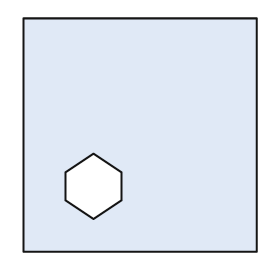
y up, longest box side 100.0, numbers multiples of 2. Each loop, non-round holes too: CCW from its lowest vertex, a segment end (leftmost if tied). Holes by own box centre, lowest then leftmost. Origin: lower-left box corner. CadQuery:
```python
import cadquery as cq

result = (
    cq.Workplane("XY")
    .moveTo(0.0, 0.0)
    .lineTo(100.0, 0.0)
    .lineTo(100.0, 100.0)
    .lineTo(0.0, 100.0)
    .close()
    .moveTo(30.0, 14.0)
    .lineTo(42.0, 22.0)
    .lineTo(42.0, 34.0)
    .lineTo(30.0, 42.0)
    .lineTo(18.0, 34.0)
    .lineTo(18.0, 22.0)
    .close()
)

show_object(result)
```